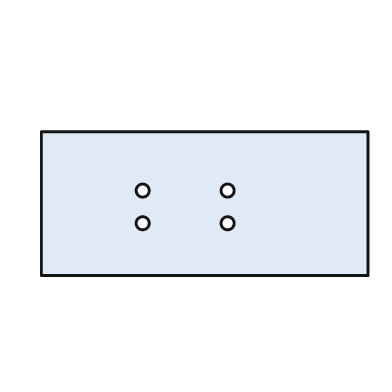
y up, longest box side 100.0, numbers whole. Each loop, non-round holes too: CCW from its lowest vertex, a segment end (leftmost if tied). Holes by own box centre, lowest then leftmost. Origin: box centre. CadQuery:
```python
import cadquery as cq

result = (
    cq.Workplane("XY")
    .moveTo(-50.0, -22.0)
    .lineTo(50.0, -22.0)
    .lineTo(50.0, 22.0)
    .lineTo(-50.0, 22.0)
    .close()
    .moveTo(-19.0, -6.0)
    .circle(2.0)
    .moveTo(7.0, -6.0)
    .circle(2.0)
    .moveTo(-19.0, 4.0)
    .circle(2.0)
    .moveTo(7.0, 4.0)
    .circle(2.0)
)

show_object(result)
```